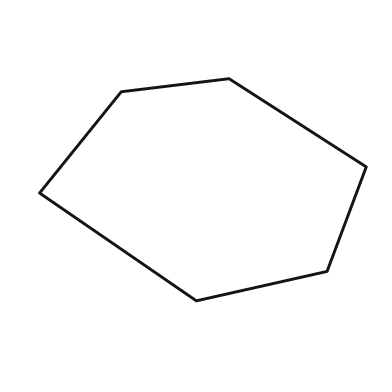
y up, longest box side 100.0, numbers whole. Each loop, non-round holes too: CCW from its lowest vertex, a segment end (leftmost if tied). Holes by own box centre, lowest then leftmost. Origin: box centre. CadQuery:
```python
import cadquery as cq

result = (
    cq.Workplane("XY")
    .moveTo(-2.0, -34.0)
    .lineTo(38.0, -25.0)
    .lineTo(50.0, 7.0)
    .lineTo(8.0, 34.0)
    .lineTo(-25.0, 30.0)
    .lineTo(-50.0, -1.0)
    .close()
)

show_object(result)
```